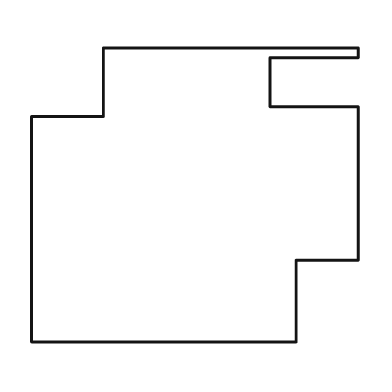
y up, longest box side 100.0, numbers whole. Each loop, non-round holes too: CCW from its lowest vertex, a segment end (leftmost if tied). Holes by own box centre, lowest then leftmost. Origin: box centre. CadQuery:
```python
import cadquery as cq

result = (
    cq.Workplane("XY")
    .moveTo(-50.0, -45.0)
    .lineTo(31.0, -45.0)
    .lineTo(31.0, -20.0)
    .lineTo(50.0, -20.0)
    .lineTo(50.0, 27.0)
    .lineTo(23.0, 27.0)
    .lineTo(23.0, 42.0)
    .lineTo(50.0, 42.0)
    .lineTo(50.0, 45.0)
    .lineTo(-28.0, 45.0)
    .lineTo(-28.0, 24.0)
    .lineTo(-50.0, 24.0)
    .close()
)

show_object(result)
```